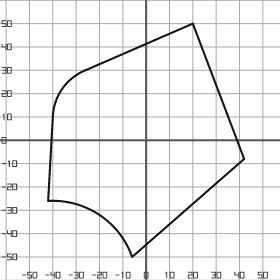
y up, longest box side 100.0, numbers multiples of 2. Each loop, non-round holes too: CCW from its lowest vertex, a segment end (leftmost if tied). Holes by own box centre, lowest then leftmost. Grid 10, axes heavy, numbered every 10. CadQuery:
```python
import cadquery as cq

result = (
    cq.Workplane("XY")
    .moveTo(-6.0, -50.0)
    .lineTo(42.0, -8.0)
    .lineTo(20.0, 50.0)
    .lineTo(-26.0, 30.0)
    .threePointArc((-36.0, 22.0), (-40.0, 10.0))
    .lineTo(-42.0, -26.0)
    .threePointArc((-20.0, -32.0), (-6.0, -50.0))
    .close()
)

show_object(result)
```